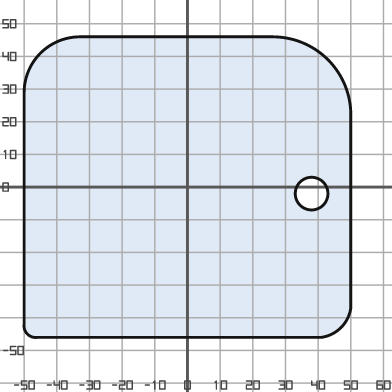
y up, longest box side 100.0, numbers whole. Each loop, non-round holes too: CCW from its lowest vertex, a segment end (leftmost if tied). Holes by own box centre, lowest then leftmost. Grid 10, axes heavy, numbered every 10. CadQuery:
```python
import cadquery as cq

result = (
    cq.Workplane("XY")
    .moveTo(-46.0, -46.0)
    .lineTo(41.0, -46.0)
    .threePointArc((47.0, -43.0), (50.0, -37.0))
    .lineTo(50.0, 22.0)
    .threePointArc((43.0, 39.0), (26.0, 46.0))
    .lineTo(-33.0, 46.0)
    .threePointArc((-45.0, 41.0), (-50.0, 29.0))
    .lineTo(-50.0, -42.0)
    .threePointArc((-49.0, -45.0), (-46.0, -46.0))
    .close()
    .moveTo(38.0, -2.0)
    .circle(5.0)
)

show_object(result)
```